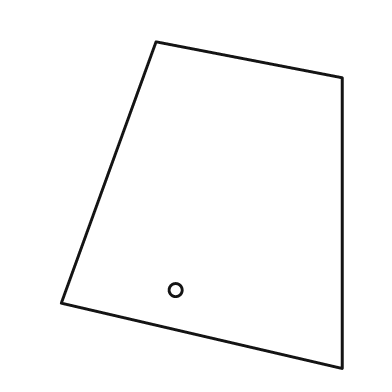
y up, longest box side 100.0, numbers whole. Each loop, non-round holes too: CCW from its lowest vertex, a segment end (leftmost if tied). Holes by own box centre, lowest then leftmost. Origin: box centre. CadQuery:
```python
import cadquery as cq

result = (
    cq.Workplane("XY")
    .moveTo(43.0, -50.0)
    .lineTo(43.0, 39.0)
    .lineTo(-14.0, 50.0)
    .lineTo(-43.0, -30.0)
    .close()
    .moveTo(-8.0, -26.0)
    .circle(2.0)
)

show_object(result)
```